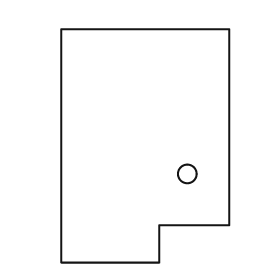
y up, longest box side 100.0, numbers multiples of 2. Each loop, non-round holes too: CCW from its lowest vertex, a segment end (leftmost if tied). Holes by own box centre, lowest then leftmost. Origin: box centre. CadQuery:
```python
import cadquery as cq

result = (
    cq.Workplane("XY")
    .moveTo(-36.0, -50.0)
    .lineTo(6.0, -50.0)
    .lineTo(6.0, -34.0)
    .lineTo(36.0, -34.0)
    .lineTo(36.0, 50.0)
    .lineTo(-36.0, 50.0)
    .close()
    .moveTo(18.0, -12.0)
    .circle(4.0)
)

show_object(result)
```